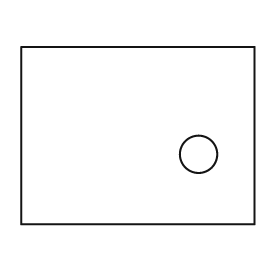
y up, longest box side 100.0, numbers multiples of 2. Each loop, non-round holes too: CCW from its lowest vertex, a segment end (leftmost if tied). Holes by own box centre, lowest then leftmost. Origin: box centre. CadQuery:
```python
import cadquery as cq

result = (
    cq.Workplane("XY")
    .moveTo(-50.0, -38.0)
    .lineTo(50.0, -38.0)
    .lineTo(50.0, 38.0)
    .lineTo(-50.0, 38.0)
    .close()
    .moveTo(26.0, -8.0)
    .circle(8.0)
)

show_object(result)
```